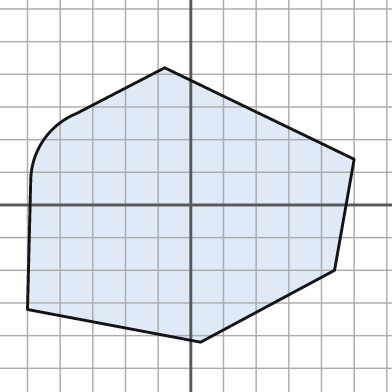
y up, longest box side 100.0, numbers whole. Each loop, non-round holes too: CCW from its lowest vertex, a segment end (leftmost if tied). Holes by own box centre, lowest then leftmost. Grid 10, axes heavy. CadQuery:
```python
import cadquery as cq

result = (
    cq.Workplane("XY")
    .moveTo(3.0, -42.0)
    .lineTo(44.0, -20.0)
    .lineTo(50.0, 14.0)
    .lineTo(-8.0, 42.0)
    .lineTo(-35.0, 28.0)
    .threePointArc((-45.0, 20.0), (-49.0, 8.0))
    .lineTo(-50.0, -32.0)
    .close()
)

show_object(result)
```